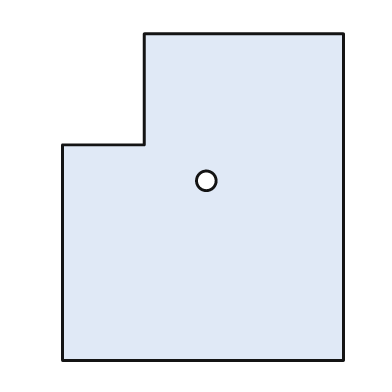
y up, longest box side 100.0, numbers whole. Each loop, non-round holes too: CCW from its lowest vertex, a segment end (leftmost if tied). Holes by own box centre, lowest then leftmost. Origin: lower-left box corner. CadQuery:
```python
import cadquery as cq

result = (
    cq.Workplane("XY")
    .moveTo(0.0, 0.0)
    .lineTo(86.0, 0.0)
    .lineTo(86.0, 100.0)
    .lineTo(25.0, 100.0)
    .lineTo(25.0, 66.0)
    .lineTo(0.0, 66.0)
    .close()
    .moveTo(44.0, 55.0)
    .circle(3.0)
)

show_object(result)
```